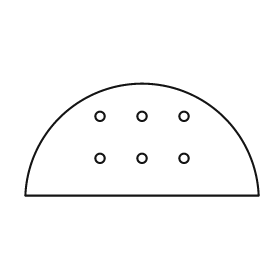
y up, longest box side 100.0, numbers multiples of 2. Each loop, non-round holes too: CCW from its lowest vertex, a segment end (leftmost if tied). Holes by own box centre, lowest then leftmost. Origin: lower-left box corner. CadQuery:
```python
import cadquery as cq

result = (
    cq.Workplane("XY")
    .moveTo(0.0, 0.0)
    .lineTo(100.0, 0.0)
    .threePointArc((50.0, 48.0), (0.0, 0.0))
    .close()
    .moveTo(32.0, 16.0)
    .circle(2.0)
    .moveTo(50.0, 16.0)
    .circle(2.0)
    .moveTo(68.0, 16.0)
    .circle(2.0)
    .moveTo(32.0, 34.0)
    .circle(2.0)
    .moveTo(50.0, 34.0)
    .circle(2.0)
    .moveTo(68.0, 34.0)
    .circle(2.0)
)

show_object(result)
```